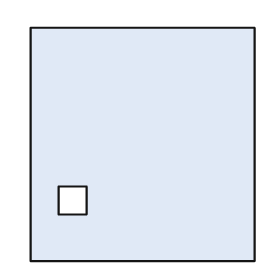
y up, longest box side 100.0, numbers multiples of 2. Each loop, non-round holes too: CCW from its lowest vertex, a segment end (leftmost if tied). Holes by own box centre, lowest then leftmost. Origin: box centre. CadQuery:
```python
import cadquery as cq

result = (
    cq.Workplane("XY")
    .moveTo(-48.0, -50.0)
    .lineTo(48.0, -50.0)
    .lineTo(48.0, 50.0)
    .lineTo(-48.0, 50.0)
    .close()
    .moveTo(-36.0, -30.0)
    .lineTo(-24.0, -30.0)
    .lineTo(-24.0, -18.0)
    .lineTo(-36.0, -18.0)
    .close()
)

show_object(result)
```